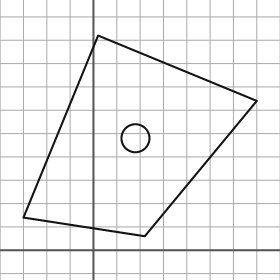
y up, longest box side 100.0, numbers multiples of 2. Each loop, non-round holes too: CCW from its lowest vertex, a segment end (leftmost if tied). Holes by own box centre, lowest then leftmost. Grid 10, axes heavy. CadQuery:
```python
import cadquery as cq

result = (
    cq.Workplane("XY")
    .moveTo(22.0, 6.0)
    .lineTo(70.0, 64.0)
    .lineTo(2.0, 92.0)
    .lineTo(-30.0, 14.0)
    .close()
    .moveTo(18.0, 48.0)
    .circle(6.0)
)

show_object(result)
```